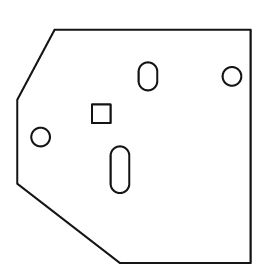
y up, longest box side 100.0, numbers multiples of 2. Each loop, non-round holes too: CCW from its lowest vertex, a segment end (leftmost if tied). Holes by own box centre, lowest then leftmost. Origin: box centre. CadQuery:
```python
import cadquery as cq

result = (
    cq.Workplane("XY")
    .moveTo(-6.0, -50.0)
    .lineTo(50.0, -50.0)
    .lineTo(50.0, 50.0)
    .lineTo(-34.0, 50.0)
    .lineTo(-50.0, 20.0)
    .lineTo(-50.0, -16.0)
    .close()
    .moveTo(-10.0, -16.0)
    .threePointArc((-6.0, -20.0), (-2.0, -16.0))
    .lineTo(-2.0, -4.0)
    .threePointArc((-6.0, 0.0), (-10.0, -4.0))
    .close()
    .moveTo(-40.0, 4.0)
    .circle(4.0)
    .moveTo(-18.0, 10.0)
    .lineTo(-10.0, 10.0)
    .lineTo(-10.0, 18.0)
    .lineTo(-18.0, 18.0)
    .close()
    .moveTo(2.0, 28.0)
    .threePointArc((6.0, 24.0), (10.0, 28.0))
    .lineTo(10.0, 32.0)
    .threePointArc((6.0, 36.0), (2.0, 32.0))
    .close()
    .moveTo(42.0, 30.0)
    .circle(4.0)
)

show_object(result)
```